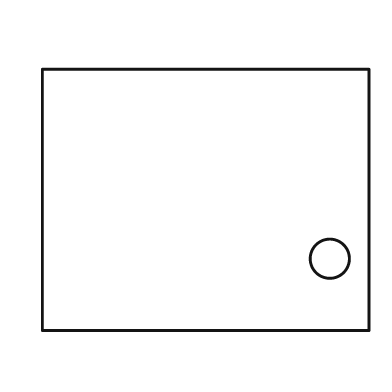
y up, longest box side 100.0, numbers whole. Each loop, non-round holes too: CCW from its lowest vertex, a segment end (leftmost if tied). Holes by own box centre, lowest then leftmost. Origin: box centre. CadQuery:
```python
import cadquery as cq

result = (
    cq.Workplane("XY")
    .moveTo(-50.0, -40.0)
    .lineTo(50.0, -40.0)
    .lineTo(50.0, 40.0)
    .lineTo(-50.0, 40.0)
    .close()
    .moveTo(38.0, -18.0)
    .circle(6.0)
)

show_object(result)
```